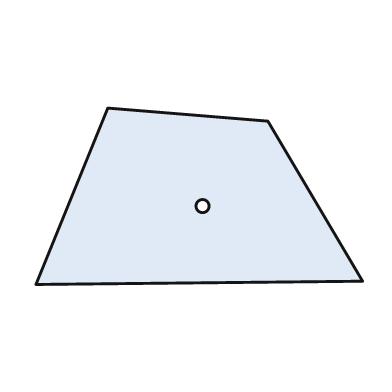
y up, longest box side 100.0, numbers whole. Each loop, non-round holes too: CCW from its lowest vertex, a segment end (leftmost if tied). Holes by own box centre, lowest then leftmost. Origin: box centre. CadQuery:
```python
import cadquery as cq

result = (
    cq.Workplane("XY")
    .moveTo(-50.0, -27.0)
    .lineTo(50.0, -26.0)
    .lineTo(21.0, 23.0)
    .lineTo(-28.0, 27.0)
    .close()
    .moveTo(1.0, -3.0)
    .circle(2.0)
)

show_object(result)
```